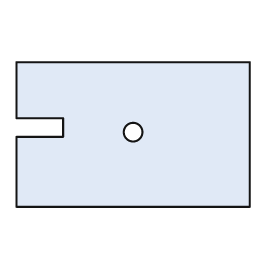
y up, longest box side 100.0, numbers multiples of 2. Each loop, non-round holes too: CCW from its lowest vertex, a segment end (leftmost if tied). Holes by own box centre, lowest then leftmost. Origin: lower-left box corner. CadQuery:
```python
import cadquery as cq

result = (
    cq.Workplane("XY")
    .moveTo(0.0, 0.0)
    .lineTo(100.0, 0.0)
    .lineTo(100.0, 62.0)
    .lineTo(0.0, 62.0)
    .lineTo(0.0, 38.0)
    .lineTo(20.0, 38.0)
    .lineTo(20.0, 30.0)
    .lineTo(0.0, 30.0)
    .close()
    .moveTo(50.0, 32.0)
    .circle(4.0)
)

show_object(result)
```